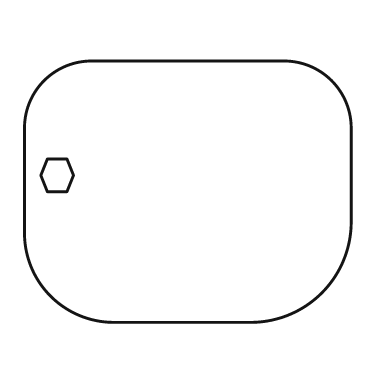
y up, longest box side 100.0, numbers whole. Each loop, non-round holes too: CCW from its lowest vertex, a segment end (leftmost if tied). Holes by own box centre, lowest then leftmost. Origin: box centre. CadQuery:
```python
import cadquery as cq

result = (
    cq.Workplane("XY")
    .moveTo(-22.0, -40.0)
    .lineTo(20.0, -40.0)
    .threePointArc((41.0, -31.0), (50.0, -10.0))
    .lineTo(50.0, 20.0)
    .threePointArc((44.0, 34.0), (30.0, 40.0))
    .lineTo(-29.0, 40.0)
    .threePointArc((-44.0, 34.0), (-50.0, 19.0))
    .lineTo(-50.0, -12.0)
    .threePointArc((-42.0, -32.0), (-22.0, -40.0))
    .close()
    .moveTo(-43.0, 0.0)
    .lineTo(-37.0, 0.0)
    .lineTo(-35.0, 5.0)
    .lineTo(-37.0, 10.0)
    .lineTo(-43.0, 10.0)
    .lineTo(-45.0, 5.0)
    .close()
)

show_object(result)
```